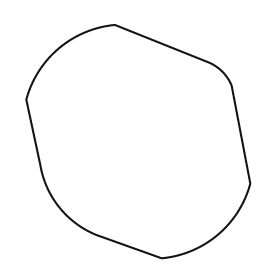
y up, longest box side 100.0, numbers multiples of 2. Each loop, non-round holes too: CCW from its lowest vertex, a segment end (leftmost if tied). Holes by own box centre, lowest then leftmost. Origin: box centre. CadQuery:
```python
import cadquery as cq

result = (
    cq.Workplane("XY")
    .moveTo(10.0, -50.0)
    .threePointArc((34.0, -40.0), (48.0, -18.0))
    .lineTo(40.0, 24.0)
    .threePointArc((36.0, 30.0), (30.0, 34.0))
    .lineTo(-10.0, 50.0)
    .threePointArc((-34.0, 40.0), (-48.0, 18.0))
    .lineTo(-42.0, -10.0)
    .threePointArc((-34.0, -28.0), (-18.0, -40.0))
    .close()
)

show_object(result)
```